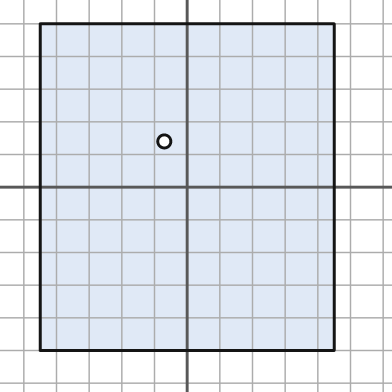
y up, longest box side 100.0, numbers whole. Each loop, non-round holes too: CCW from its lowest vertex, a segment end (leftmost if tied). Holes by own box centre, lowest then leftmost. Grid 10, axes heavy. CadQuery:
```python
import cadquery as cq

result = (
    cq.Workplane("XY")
    .moveTo(-45.0, -50.0)
    .lineTo(45.0, -50.0)
    .lineTo(45.0, 50.0)
    .lineTo(-45.0, 50.0)
    .close()
    .moveTo(-7.0, 14.0)
    .circle(2.0)
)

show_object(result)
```